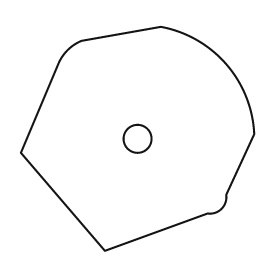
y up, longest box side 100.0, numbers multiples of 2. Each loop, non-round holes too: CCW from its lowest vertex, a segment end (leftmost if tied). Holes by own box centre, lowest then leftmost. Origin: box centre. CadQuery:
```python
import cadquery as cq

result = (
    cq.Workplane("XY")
    .moveTo(-14.0, -48.0)
    .lineTo(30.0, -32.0)
    .threePointArc((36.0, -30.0), (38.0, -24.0))
    .lineTo(50.0, 2.0)
    .threePointArc((38.0, 32.0), (10.0, 48.0))
    .lineTo(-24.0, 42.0)
    .threePointArc((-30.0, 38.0), (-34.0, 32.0))
    .lineTo(-50.0, -6.0)
    .close()
    .moveTo(0.0, 0.0)
    .circle(6.0)
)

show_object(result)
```